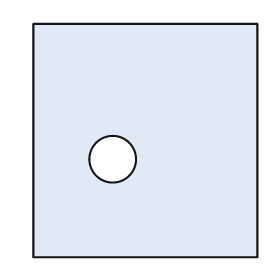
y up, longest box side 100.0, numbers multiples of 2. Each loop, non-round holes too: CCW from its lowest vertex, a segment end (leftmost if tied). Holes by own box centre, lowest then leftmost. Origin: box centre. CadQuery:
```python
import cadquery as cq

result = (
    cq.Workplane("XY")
    .moveTo(-48.0, -50.0)
    .lineTo(48.0, -50.0)
    .lineTo(48.0, 50.0)
    .lineTo(-48.0, 50.0)
    .close()
    .moveTo(-14.0, -8.0)
    .circle(10.0)
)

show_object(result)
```